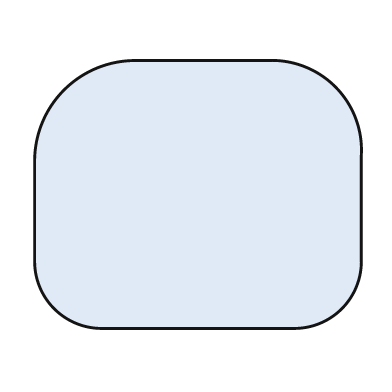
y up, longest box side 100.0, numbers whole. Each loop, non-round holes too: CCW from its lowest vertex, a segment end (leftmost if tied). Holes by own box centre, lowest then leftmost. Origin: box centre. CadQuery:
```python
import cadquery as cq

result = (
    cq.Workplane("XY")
    .moveTo(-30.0, -41.0)
    .lineTo(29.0, -41.0)
    .threePointArc((44.0, -35.0), (50.0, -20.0))
    .lineTo(50.0, 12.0)
    .threePointArc((42.0, 33.0), (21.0, 41.0))
    .lineTo(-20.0, 41.0)
    .threePointArc((-41.0, 32.0), (-50.0, 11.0))
    .lineTo(-50.0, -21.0)
    .threePointArc((-44.0, -35.0), (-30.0, -41.0))
    .close()
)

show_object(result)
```